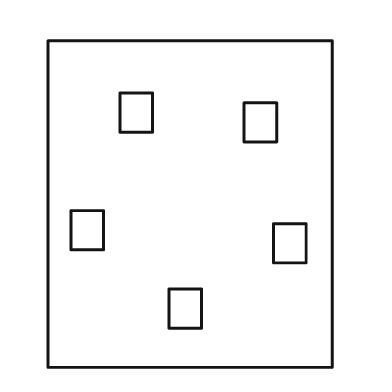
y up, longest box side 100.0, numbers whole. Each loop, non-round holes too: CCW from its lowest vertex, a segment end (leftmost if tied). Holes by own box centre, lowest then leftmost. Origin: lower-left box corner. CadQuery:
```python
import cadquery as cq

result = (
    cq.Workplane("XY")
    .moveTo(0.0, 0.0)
    .lineTo(87.0, 0.0)
    .lineTo(87.0, 100.0)
    .lineTo(0.0, 100.0)
    .close()
    .moveTo(37.0, 12.0)
    .lineTo(47.0, 12.0)
    .lineTo(47.0, 24.0)
    .lineTo(37.0, 24.0)
    .close()
    .moveTo(69.0, 32.0)
    .lineTo(79.0, 32.0)
    .lineTo(79.0, 44.0)
    .lineTo(69.0, 44.0)
    .close()
    .moveTo(7.0, 36.0)
    .lineTo(17.0, 36.0)
    .lineTo(17.0, 48.0)
    .lineTo(7.0, 48.0)
    .close()
    .moveTo(60.0, 69.0)
    .lineTo(70.0, 69.0)
    .lineTo(70.0, 81.0)
    .lineTo(60.0, 81.0)
    .close()
    .moveTo(22.0, 72.0)
    .lineTo(32.0, 72.0)
    .lineTo(32.0, 84.0)
    .lineTo(22.0, 84.0)
    .close()
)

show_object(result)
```